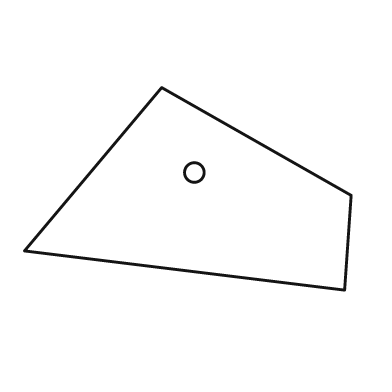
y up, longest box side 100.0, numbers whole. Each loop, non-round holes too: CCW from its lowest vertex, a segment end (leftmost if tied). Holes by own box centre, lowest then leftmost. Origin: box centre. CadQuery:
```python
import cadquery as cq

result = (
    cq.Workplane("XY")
    .moveTo(48.0, -31.0)
    .lineTo(50.0, -2.0)
    .lineTo(-8.0, 31.0)
    .lineTo(-50.0, -19.0)
    .close()
    .moveTo(2.0, 5.0)
    .circle(3.0)
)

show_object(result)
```